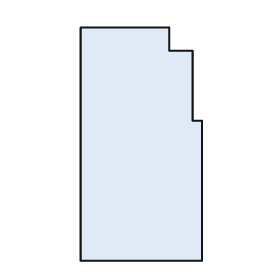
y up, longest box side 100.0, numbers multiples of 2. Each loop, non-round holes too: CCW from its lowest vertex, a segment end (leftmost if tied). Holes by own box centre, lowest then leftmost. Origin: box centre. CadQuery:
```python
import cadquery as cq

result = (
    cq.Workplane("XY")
    .moveTo(-26.0, -50.0)
    .lineTo(26.0, -50.0)
    .lineTo(26.0, 10.0)
    .lineTo(22.0, 10.0)
    .lineTo(22.0, 40.0)
    .lineTo(12.0, 40.0)
    .lineTo(12.0, 50.0)
    .lineTo(-26.0, 50.0)
    .close()
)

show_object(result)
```